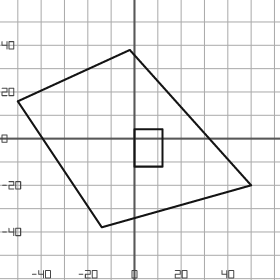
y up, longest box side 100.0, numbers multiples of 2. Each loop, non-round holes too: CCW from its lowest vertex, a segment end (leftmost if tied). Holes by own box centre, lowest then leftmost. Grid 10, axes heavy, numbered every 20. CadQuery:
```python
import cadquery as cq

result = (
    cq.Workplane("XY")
    .moveTo(-14.0, -38.0)
    .lineTo(50.0, -20.0)
    .lineTo(-2.0, 38.0)
    .lineTo(-50.0, 16.0)
    .close()
    .moveTo(0.0, -12.0)
    .lineTo(12.0, -12.0)
    .lineTo(12.0, 4.0)
    .lineTo(0.0, 4.0)
    .close()
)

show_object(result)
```